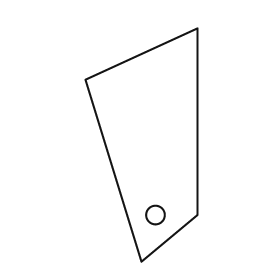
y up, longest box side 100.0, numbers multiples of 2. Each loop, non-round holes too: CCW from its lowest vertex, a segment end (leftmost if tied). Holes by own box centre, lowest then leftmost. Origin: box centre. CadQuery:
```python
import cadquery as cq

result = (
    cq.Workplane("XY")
    .moveTo(0.0, -50.0)
    .lineTo(24.0, -30.0)
    .lineTo(24.0, 50.0)
    .lineTo(-24.0, 28.0)
    .close()
    .moveTo(6.0, -30.0)
    .circle(4.0)
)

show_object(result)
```